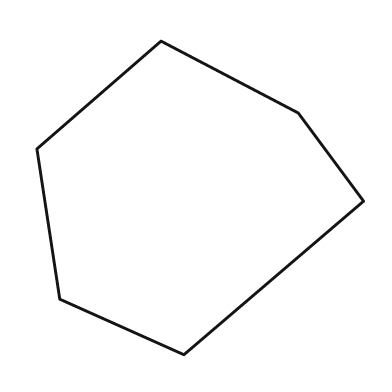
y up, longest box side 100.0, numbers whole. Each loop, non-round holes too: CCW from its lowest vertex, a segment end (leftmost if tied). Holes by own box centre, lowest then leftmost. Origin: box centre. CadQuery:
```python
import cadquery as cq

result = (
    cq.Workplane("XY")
    .moveTo(-5.0, -48.0)
    .lineTo(50.0, -1.0)
    .lineTo(30.0, 26.0)
    .lineTo(-12.0, 48.0)
    .lineTo(-50.0, 15.0)
    .lineTo(-43.0, -31.0)
    .close()
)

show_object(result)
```